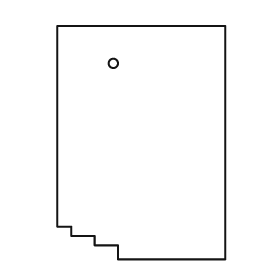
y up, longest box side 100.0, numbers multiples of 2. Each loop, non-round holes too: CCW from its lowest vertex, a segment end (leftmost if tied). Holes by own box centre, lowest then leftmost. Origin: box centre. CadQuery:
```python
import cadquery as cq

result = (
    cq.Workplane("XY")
    .moveTo(-10.0, -50.0)
    .lineTo(36.0, -50.0)
    .lineTo(36.0, 50.0)
    .lineTo(-36.0, 50.0)
    .lineTo(-36.0, -36.0)
    .lineTo(-30.0, -36.0)
    .lineTo(-30.0, -40.0)
    .lineTo(-20.0, -40.0)
    .lineTo(-20.0, -44.0)
    .lineTo(-10.0, -44.0)
    .close()
    .moveTo(-12.0, 34.0)
    .circle(2.0)
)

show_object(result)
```